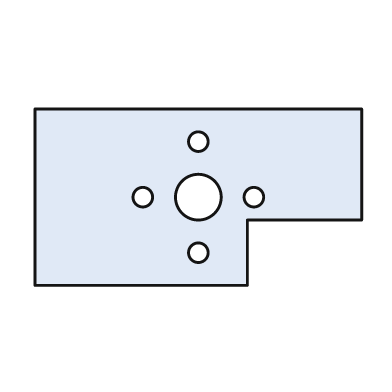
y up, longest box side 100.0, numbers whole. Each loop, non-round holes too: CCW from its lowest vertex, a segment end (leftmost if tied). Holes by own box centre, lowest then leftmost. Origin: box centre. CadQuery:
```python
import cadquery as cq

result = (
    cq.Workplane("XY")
    .moveTo(-50.0, -27.0)
    .lineTo(15.0, -27.0)
    .lineTo(15.0, -7.0)
    .lineTo(50.0, -7.0)
    .lineTo(50.0, 27.0)
    .lineTo(-50.0, 27.0)
    .close()
    .moveTo(0.0, -17.0)
    .circle(3.0)
    .moveTo(-17.0, 0.0)
    .circle(3.0)
    .moveTo(0.0, 0.0)
    .circle(7.0)
    .moveTo(17.0, 0.0)
    .circle(3.0)
    .moveTo(0.0, 17.0)
    .circle(3.0)
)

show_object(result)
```